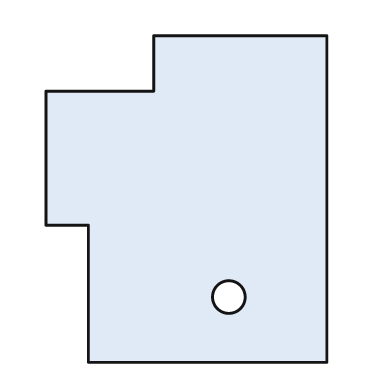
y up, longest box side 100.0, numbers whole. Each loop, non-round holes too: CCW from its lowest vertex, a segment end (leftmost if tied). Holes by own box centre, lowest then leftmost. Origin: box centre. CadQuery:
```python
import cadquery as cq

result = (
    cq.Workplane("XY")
    .moveTo(-30.0, -50.0)
    .lineTo(43.0, -50.0)
    .lineTo(43.0, 50.0)
    .lineTo(-10.0, 50.0)
    .lineTo(-10.0, 33.0)
    .lineTo(-43.0, 33.0)
    .lineTo(-43.0, -8.0)
    .lineTo(-30.0, -8.0)
    .close()
    .moveTo(13.0, -30.0)
    .circle(5.0)
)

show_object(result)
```